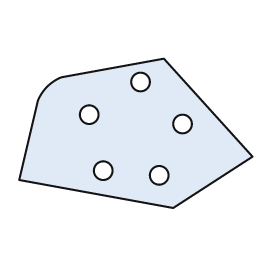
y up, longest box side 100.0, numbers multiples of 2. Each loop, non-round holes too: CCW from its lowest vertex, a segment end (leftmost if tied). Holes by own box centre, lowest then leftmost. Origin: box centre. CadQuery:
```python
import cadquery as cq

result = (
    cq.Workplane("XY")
    .moveTo(16.0, -32.0)
    .lineTo(50.0, -10.0)
    .lineTo(12.0, 32.0)
    .lineTo(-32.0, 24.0)
    .threePointArc((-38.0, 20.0), (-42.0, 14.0))
    .lineTo(-50.0, -20.0)
    .close()
    .moveTo(10.0, -18.0)
    .circle(4.0)
    .moveTo(-14.0, -16.0)
    .circle(4.0)
    .moveTo(20.0, 4.0)
    .circle(4.0)
    .moveTo(-20.0, 8.0)
    .circle(4.0)
    .moveTo(2.0, 22.0)
    .circle(4.0)
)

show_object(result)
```